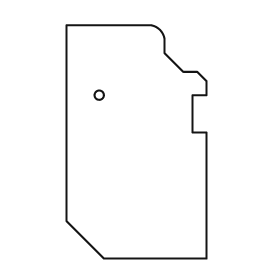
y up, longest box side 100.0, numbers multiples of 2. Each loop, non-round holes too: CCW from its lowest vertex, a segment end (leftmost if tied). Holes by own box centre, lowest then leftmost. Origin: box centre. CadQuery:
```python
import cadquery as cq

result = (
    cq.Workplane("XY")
    .moveTo(-14.0, -50.0)
    .lineTo(30.0, -50.0)
    .lineTo(30.0, 4.0)
    .lineTo(24.0, 4.0)
    .lineTo(24.0, 20.0)
    .lineTo(30.0, 20.0)
    .lineTo(30.0, 26.0)
    .lineTo(26.0, 30.0)
    .lineTo(20.0, 30.0)
    .lineTo(12.0, 38.0)
    .lineTo(12.0, 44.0)
    .threePointArc((10.0, 48.0), (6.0, 50.0))
    .lineTo(-30.0, 50.0)
    .lineTo(-30.0, -34.0)
    .close()
    .moveTo(-16.0, 20.0)
    .circle(2.0)
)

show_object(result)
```